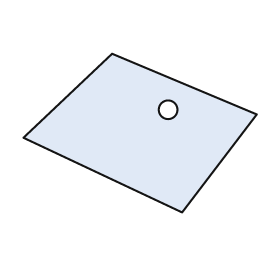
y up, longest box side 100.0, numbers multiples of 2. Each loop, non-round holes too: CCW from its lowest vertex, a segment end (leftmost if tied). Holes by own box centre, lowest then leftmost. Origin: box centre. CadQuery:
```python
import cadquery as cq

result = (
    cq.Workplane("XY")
    .moveTo(18.0, -34.0)
    .lineTo(50.0, 8.0)
    .lineTo(-12.0, 34.0)
    .lineTo(-50.0, -2.0)
    .close()
    .moveTo(12.0, 10.0)
    .circle(4.0)
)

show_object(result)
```